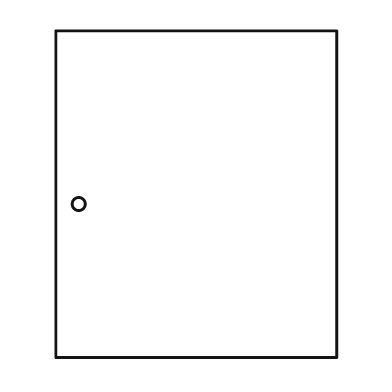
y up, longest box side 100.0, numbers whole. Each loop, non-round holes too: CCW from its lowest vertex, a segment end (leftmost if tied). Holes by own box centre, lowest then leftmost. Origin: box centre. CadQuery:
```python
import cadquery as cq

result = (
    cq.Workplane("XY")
    .moveTo(-43.0, -50.0)
    .lineTo(43.0, -50.0)
    .lineTo(43.0, 50.0)
    .lineTo(-43.0, 50.0)
    .close()
    .moveTo(-36.0, -3.0)
    .circle(2.0)
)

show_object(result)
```